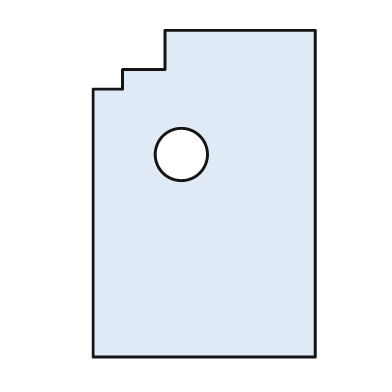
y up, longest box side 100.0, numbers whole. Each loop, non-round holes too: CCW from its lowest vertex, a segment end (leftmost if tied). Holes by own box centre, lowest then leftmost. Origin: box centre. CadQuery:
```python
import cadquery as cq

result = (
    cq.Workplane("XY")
    .moveTo(-34.0, -50.0)
    .lineTo(34.0, -50.0)
    .lineTo(34.0, 50.0)
    .lineTo(-12.0, 50.0)
    .lineTo(-12.0, 38.0)
    .lineTo(-25.0, 38.0)
    .lineTo(-25.0, 32.0)
    .lineTo(-34.0, 32.0)
    .close()
    .moveTo(-7.0, 12.0)
    .circle(8.0)
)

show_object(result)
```